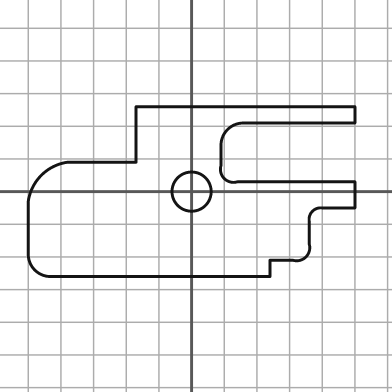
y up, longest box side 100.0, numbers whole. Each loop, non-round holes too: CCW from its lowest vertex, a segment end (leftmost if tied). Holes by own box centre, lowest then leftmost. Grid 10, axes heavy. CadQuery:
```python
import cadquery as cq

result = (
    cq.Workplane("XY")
    .moveTo(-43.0, -26.0)
    .lineTo(24.0, -26.0)
    .lineTo(24.0, -21.0)
    .lineTo(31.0, -21.0)
    .threePointArc((35.0, -20.0), (36.0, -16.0))
    .lineTo(36.0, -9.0)
    .threePointArc((37.0, -6.0), (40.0, -5.0))
    .lineTo(50.0, -5.0)
    .lineTo(50.0, 3.0)
    .lineTo(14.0, 3.0)
    .threePointArc((10.0, 4.0), (9.0, 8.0))
    .lineTo(9.0, 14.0)
    .threePointArc((11.0, 19.0), (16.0, 21.0))
    .lineTo(50.0, 21.0)
    .lineTo(50.0, 26.0)
    .lineTo(-17.0, 26.0)
    .lineTo(-17.0, 9.0)
    .lineTo(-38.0, 9.0)
    .threePointArc((-46.0, 5.0), (-50.0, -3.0))
    .lineTo(-50.0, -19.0)
    .threePointArc((-48.0, -24.0), (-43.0, -26.0))
    .close()
    .moveTo(0.0, 0.0)
    .circle(6.0)
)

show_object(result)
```